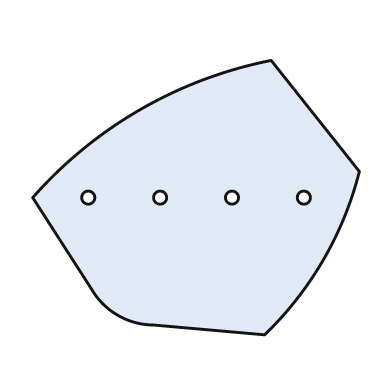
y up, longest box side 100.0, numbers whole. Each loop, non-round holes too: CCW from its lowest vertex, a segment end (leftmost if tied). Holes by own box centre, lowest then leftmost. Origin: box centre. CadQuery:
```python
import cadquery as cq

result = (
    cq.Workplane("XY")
    .moveTo(21.0, -42.0)
    .threePointArc((39.0, -19.0), (50.0, 8.0))
    .lineTo(23.0, 42.0)
    .threePointArc((-17.0, 27.0), (-50.0, 0.0))
    .lineTo(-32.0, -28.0)
    .threePointArc((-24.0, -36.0), (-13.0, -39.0))
    .close()
    .moveTo(-33.0, 0.0)
    .circle(2.0)
    .moveTo(-11.0, 0.0)
    .circle(2.0)
    .moveTo(11.0, 0.0)
    .circle(2.0)
    .moveTo(33.0, 0.0)
    .circle(2.0)
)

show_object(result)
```